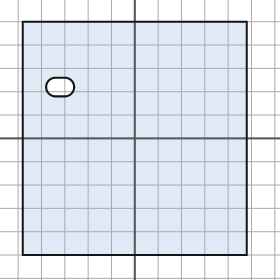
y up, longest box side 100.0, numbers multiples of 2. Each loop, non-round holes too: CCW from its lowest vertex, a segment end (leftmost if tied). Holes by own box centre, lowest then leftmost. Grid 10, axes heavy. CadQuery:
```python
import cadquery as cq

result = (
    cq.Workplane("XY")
    .moveTo(-48.0, -50.0)
    .lineTo(48.0, -50.0)
    .lineTo(48.0, 50.0)
    .lineTo(-48.0, 50.0)
    .close()
    .moveTo(-34.0, 18.0)
    .lineTo(-30.0, 18.0)
    .threePointArc((-26.0, 22.0), (-30.0, 26.0))
    .lineTo(-34.0, 26.0)
    .threePointArc((-38.0, 22.0), (-34.0, 18.0))
    .close()
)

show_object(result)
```